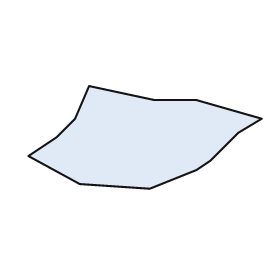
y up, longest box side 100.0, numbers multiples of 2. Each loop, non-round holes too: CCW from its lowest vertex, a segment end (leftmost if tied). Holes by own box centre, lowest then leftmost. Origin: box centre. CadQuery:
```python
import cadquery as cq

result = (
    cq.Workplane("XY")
    .moveTo(2.0, -22.0)
    .lineTo(22.0, -14.0)
    .lineTo(28.0, -10.0)
    .lineTo(40.0, 2.0)
    .lineTo(50.0, 8.0)
    .lineTo(22.0, 16.0)
    .lineTo(4.0, 16.0)
    .lineTo(-24.0, 22.0)
    .lineTo(-30.0, 8.0)
    .lineTo(-38.0, 0.0)
    .lineTo(-50.0, -8.0)
    .lineTo(-28.0, -20.0)
    .close()
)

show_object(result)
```